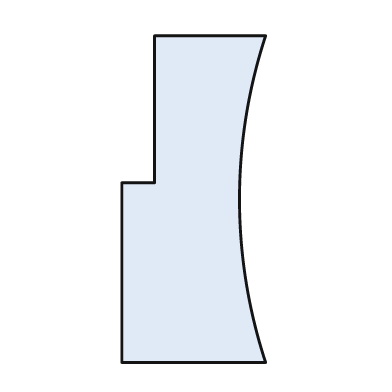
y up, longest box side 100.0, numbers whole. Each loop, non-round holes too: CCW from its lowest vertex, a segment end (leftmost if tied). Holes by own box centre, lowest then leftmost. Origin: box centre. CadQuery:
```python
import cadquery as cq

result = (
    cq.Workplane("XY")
    .moveTo(-22.0, -50.0)
    .lineTo(22.0, -50.0)
    .threePointArc((14.0, 0.0), (22.0, 50.0))
    .lineTo(-12.0, 50.0)
    .lineTo(-12.0, 5.0)
    .lineTo(-22.0, 5.0)
    .close()
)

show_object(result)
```